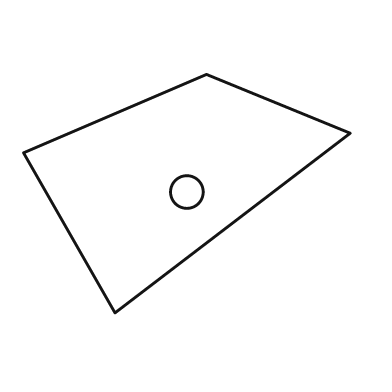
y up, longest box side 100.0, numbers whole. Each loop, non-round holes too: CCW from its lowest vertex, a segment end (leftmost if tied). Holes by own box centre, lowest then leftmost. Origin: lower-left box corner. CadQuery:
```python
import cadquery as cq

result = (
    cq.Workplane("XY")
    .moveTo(28.0, 0.0)
    .lineTo(100.0, 55.0)
    .lineTo(56.0, 73.0)
    .lineTo(0.0, 49.0)
    .close()
    .moveTo(50.0, 37.0)
    .circle(5.0)
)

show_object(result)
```